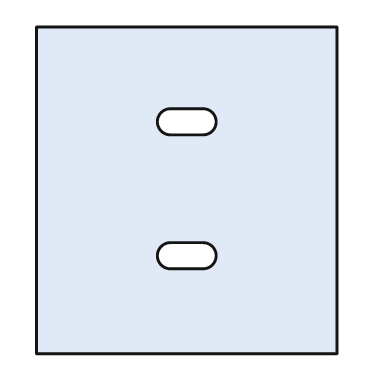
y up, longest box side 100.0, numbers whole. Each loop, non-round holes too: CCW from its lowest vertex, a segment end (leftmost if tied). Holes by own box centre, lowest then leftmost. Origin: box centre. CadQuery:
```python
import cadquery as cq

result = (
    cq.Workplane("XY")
    .moveTo(-46.0, -50.0)
    .lineTo(46.0, -50.0)
    .lineTo(46.0, 50.0)
    .lineTo(-46.0, 50.0)
    .close()
    .moveTo(-5.0, -24.0)
    .lineTo(5.0, -24.0)
    .threePointArc((9.0, -20.0), (5.0, -16.0))
    .lineTo(-5.0, -16.0)
    .threePointArc((-9.0, -20.0), (-5.0, -24.0))
    .close()
    .moveTo(-5.0, 17.0)
    .lineTo(5.0, 17.0)
    .threePointArc((9.0, 21.0), (5.0, 25.0))
    .lineTo(-5.0, 25.0)
    .threePointArc((-9.0, 21.0), (-5.0, 17.0))
    .close()
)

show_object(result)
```